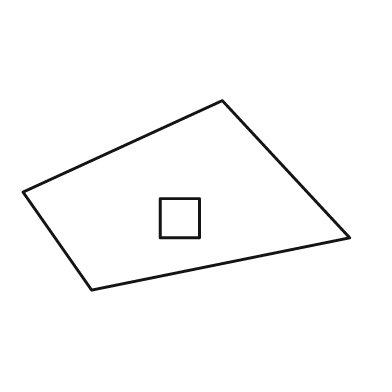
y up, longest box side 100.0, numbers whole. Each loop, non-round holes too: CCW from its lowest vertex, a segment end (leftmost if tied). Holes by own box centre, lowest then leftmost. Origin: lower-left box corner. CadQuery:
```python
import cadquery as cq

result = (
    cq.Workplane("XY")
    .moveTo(21.0, 0.0)
    .lineTo(100.0, 16.0)
    .lineTo(61.0, 58.0)
    .lineTo(0.0, 30.0)
    .close()
    .moveTo(42.0, 16.0)
    .lineTo(54.0, 16.0)
    .lineTo(54.0, 28.0)
    .lineTo(42.0, 28.0)
    .close()
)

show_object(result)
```